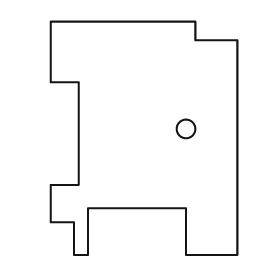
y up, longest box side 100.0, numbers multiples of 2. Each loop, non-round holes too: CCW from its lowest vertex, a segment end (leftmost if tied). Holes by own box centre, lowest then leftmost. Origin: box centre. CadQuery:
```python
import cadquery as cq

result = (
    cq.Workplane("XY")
    .moveTo(-30.0, -50.0)
    .lineTo(-24.0, -50.0)
    .lineTo(-24.0, -30.0)
    .lineTo(18.0, -30.0)
    .lineTo(18.0, -50.0)
    .lineTo(40.0, -50.0)
    .lineTo(40.0, 42.0)
    .lineTo(22.0, 42.0)
    .lineTo(22.0, 50.0)
    .lineTo(-40.0, 50.0)
    .lineTo(-40.0, 24.0)
    .lineTo(-28.0, 24.0)
    .lineTo(-28.0, -20.0)
    .lineTo(-40.0, -20.0)
    .lineTo(-40.0, -36.0)
    .lineTo(-30.0, -36.0)
    .close()
    .moveTo(18.0, 4.0)
    .circle(4.0)
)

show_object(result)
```